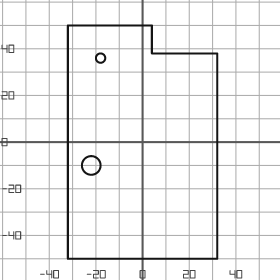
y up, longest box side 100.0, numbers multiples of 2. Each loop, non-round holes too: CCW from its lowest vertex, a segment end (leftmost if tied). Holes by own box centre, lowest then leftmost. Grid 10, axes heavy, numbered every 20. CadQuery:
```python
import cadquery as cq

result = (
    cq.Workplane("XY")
    .moveTo(-32.0, -50.0)
    .lineTo(32.0, -50.0)
    .lineTo(32.0, 38.0)
    .lineTo(4.0, 38.0)
    .lineTo(4.0, 50.0)
    .lineTo(-32.0, 50.0)
    .close()
    .moveTo(-22.0, -10.0)
    .circle(4.0)
    .moveTo(-18.0, 36.0)
    .circle(2.0)
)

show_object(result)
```